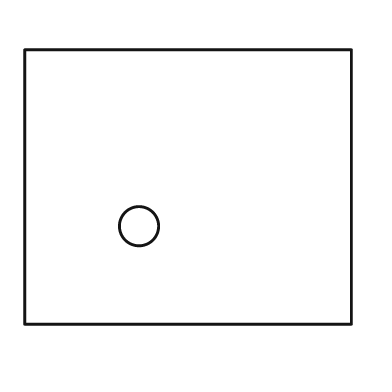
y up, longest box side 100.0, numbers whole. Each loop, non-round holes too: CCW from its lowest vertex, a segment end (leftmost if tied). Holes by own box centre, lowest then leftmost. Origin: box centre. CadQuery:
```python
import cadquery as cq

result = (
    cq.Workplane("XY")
    .moveTo(-50.0, -42.0)
    .lineTo(50.0, -42.0)
    .lineTo(50.0, 42.0)
    .lineTo(-50.0, 42.0)
    .close()
    .moveTo(-15.0, -12.0)
    .circle(6.0)
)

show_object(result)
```